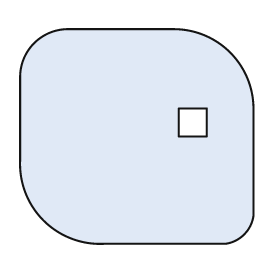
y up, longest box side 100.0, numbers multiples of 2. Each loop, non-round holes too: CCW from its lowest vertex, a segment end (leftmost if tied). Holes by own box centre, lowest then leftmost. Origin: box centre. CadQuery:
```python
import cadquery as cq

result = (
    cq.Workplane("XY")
    .moveTo(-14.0, -46.0)
    .lineTo(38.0, -46.0)
    .threePointArc((46.0, -42.0), (50.0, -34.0))
    .lineTo(50.0, 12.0)
    .threePointArc((40.0, 36.0), (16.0, 46.0))
    .lineTo(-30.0, 46.0)
    .threePointArc((-44.0, 40.0), (-50.0, 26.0))
    .lineTo(-50.0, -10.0)
    .threePointArc((-40.0, -36.0), (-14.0, -46.0))
    .close()
    .moveTo(18.0, 0.0)
    .lineTo(30.0, 0.0)
    .lineTo(30.0, 12.0)
    .lineTo(18.0, 12.0)
    .close()
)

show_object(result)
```